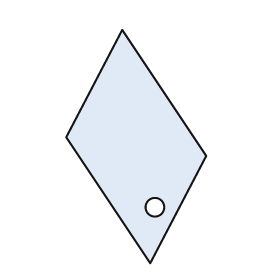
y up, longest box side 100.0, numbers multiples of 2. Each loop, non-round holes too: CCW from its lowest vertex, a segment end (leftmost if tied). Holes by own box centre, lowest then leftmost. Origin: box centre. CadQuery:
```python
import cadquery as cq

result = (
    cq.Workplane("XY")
    .moveTo(6.0, -50.0)
    .lineTo(30.0, -4.0)
    .lineTo(-6.0, 50.0)
    .lineTo(-30.0, 4.0)
    .close()
    .moveTo(8.0, -26.0)
    .circle(4.0)
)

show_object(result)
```